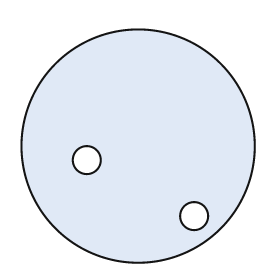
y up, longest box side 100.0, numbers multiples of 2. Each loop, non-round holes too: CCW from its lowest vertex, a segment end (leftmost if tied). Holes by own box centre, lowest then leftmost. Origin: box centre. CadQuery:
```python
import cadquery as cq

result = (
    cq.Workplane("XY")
    .moveTo(0.0, 0.0)
    .circle(50.0)
    .moveTo(24.0, -30.0)
    .circle(6.0)
    .moveTo(-22.0, -6.0)
    .circle(6.0)
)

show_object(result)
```